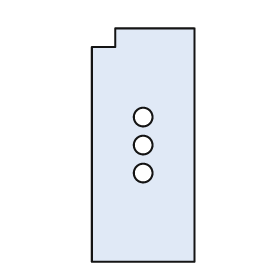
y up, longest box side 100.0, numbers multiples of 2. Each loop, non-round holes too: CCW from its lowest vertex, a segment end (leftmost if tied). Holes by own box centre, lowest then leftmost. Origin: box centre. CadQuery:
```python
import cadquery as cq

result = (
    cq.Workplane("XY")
    .moveTo(-22.0, -50.0)
    .lineTo(22.0, -50.0)
    .lineTo(22.0, 50.0)
    .lineTo(-12.0, 50.0)
    .lineTo(-12.0, 42.0)
    .lineTo(-22.0, 42.0)
    .close()
    .moveTo(0.0, -12.0)
    .circle(4.0)
    .moveTo(0.0, 0.0)
    .circle(4.0)
    .moveTo(0.0, 12.0)
    .circle(4.0)
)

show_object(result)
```